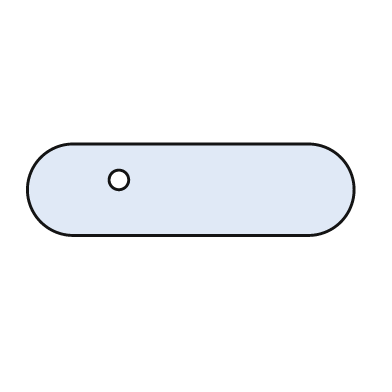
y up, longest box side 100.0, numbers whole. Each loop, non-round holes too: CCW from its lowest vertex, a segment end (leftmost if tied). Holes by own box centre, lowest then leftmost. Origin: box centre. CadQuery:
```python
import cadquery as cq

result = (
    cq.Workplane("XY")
    .moveTo(-36.0, -14.0)
    .lineTo(36.0, -14.0)
    .threePointArc((50.0, 0.0), (36.0, 14.0))
    .lineTo(-36.0, 14.0)
    .threePointArc((-50.0, 0.0), (-36.0, -14.0))
    .close()
    .moveTo(-22.0, 3.0)
    .circle(3.0)
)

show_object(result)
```